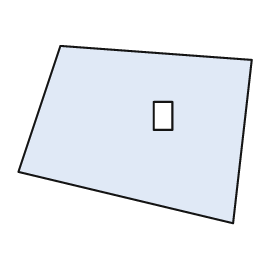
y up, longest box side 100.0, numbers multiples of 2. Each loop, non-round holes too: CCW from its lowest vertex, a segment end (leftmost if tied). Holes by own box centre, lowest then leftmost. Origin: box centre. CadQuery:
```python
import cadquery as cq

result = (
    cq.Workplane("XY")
    .moveTo(42.0, -38.0)
    .lineTo(50.0, 32.0)
    .lineTo(-32.0, 38.0)
    .lineTo(-50.0, -16.0)
    .close()
    .moveTo(8.0, 2.0)
    .lineTo(16.0, 2.0)
    .lineTo(16.0, 14.0)
    .lineTo(8.0, 14.0)
    .close()
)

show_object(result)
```